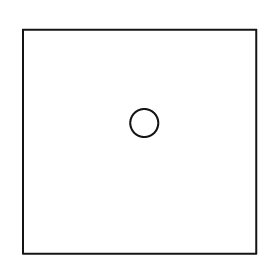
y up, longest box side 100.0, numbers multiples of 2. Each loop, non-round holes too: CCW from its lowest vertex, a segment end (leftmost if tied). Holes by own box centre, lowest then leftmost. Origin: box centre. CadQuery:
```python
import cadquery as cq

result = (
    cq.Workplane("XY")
    .moveTo(-50.0, -48.0)
    .lineTo(50.0, -48.0)
    .lineTo(50.0, 48.0)
    .lineTo(-50.0, 48.0)
    .close()
    .moveTo(2.0, 8.0)
    .circle(6.0)
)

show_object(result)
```